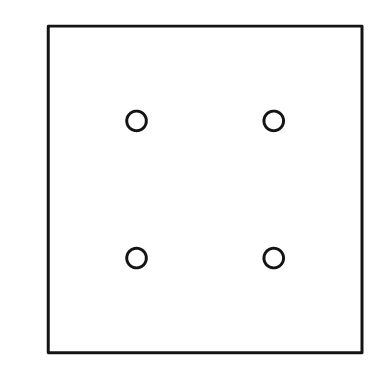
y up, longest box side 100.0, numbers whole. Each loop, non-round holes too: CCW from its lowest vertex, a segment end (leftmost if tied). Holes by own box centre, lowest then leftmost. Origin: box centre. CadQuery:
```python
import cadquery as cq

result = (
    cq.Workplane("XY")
    .moveTo(-48.0, -50.0)
    .lineTo(48.0, -50.0)
    .lineTo(48.0, 50.0)
    .lineTo(-48.0, 50.0)
    .close()
    .moveTo(-21.0, -21.0)
    .circle(3.0)
    .moveTo(21.0, -21.0)
    .circle(3.0)
    .moveTo(-21.0, 21.0)
    .circle(3.0)
    .moveTo(21.0, 21.0)
    .circle(3.0)
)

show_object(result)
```